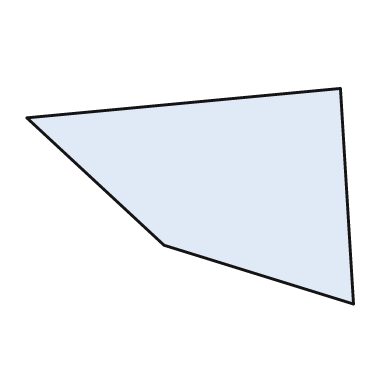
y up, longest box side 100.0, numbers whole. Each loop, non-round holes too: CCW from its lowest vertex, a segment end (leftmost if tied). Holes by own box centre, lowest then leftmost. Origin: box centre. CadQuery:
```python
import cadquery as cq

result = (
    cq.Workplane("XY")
    .moveTo(50.0, -33.0)
    .lineTo(46.0, 33.0)
    .lineTo(-50.0, 24.0)
    .lineTo(-8.0, -15.0)
    .close()
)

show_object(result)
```